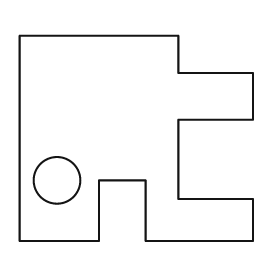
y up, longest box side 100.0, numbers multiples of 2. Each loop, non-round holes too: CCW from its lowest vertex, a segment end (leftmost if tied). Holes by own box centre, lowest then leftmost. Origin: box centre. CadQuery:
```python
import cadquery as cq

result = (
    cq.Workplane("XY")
    .moveTo(-50.0, -44.0)
    .lineTo(-16.0, -44.0)
    .lineTo(-16.0, -18.0)
    .lineTo(4.0, -18.0)
    .lineTo(4.0, -44.0)
    .lineTo(50.0, -44.0)
    .lineTo(50.0, -26.0)
    .lineTo(18.0, -26.0)
    .lineTo(18.0, 8.0)
    .lineTo(50.0, 8.0)
    .lineTo(50.0, 28.0)
    .lineTo(18.0, 28.0)
    .lineTo(18.0, 44.0)
    .lineTo(-50.0, 44.0)
    .close()
    .moveTo(-34.0, -18.0)
    .circle(10.0)
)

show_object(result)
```